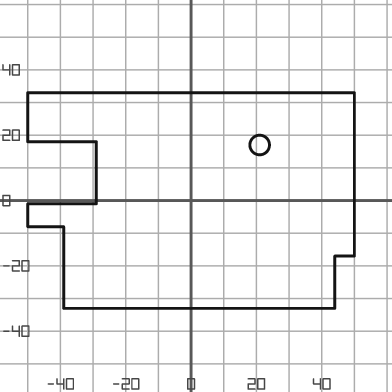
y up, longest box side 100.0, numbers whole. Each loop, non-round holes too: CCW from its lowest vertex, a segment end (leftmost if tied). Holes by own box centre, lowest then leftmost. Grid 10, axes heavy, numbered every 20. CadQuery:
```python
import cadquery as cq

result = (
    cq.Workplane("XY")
    .moveTo(-39.0, -33.0)
    .lineTo(44.0, -33.0)
    .lineTo(44.0, -17.0)
    .lineTo(50.0, -17.0)
    .lineTo(50.0, 33.0)
    .lineTo(-50.0, 33.0)
    .lineTo(-50.0, 18.0)
    .lineTo(-29.0, 18.0)
    .lineTo(-29.0, -1.0)
    .lineTo(-50.0, -1.0)
    .lineTo(-50.0, -8.0)
    .lineTo(-39.0, -8.0)
    .close()
    .moveTo(21.0, 17.0)
    .circle(3.0)
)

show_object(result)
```